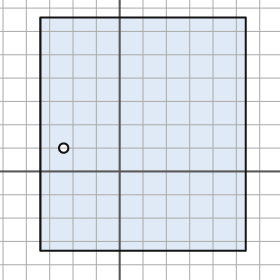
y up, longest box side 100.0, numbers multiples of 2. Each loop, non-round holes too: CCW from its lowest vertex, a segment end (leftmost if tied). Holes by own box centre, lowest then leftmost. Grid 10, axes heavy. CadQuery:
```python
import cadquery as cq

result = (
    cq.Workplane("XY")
    .moveTo(-34.0, -34.0)
    .lineTo(54.0, -34.0)
    .lineTo(54.0, 66.0)
    .lineTo(-34.0, 66.0)
    .close()
    .moveTo(-24.0, 10.0)
    .circle(2.0)
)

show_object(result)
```